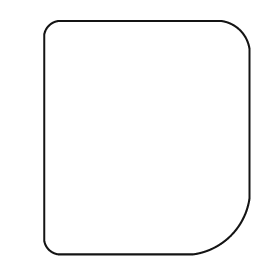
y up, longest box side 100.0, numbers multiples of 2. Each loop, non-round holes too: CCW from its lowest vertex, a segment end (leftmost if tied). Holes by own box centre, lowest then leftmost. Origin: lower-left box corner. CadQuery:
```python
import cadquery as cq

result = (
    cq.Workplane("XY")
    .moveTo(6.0, 0.0)
    .lineTo(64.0, 0.0)
    .threePointArc((80.0, 8.0), (88.0, 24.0))
    .lineTo(88.0, 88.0)
    .threePointArc((84.0, 96.0), (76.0, 100.0))
    .lineTo(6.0, 100.0)
    .threePointArc((2.0, 98.0), (0.0, 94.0))
    .lineTo(0.0, 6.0)
    .threePointArc((2.0, 2.0), (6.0, 0.0))
    .close()
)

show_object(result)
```